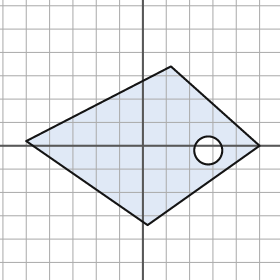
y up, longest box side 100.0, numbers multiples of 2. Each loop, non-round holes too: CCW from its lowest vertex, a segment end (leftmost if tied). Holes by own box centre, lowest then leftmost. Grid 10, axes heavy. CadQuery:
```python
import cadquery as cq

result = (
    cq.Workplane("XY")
    .moveTo(2.0, -34.0)
    .lineTo(50.0, 0.0)
    .lineTo(12.0, 34.0)
    .lineTo(-50.0, 2.0)
    .close()
    .moveTo(28.0, -2.0)
    .circle(6.0)
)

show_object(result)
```